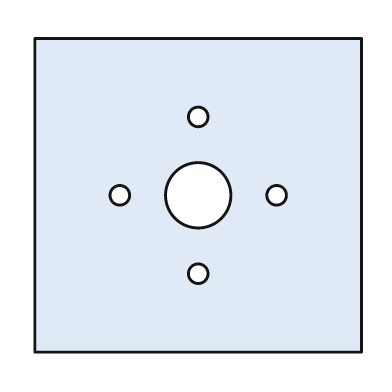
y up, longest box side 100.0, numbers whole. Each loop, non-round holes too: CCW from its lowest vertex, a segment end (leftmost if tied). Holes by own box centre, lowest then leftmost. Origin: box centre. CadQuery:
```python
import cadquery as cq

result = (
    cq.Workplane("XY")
    .moveTo(-50.0, -48.0)
    .lineTo(50.0, -48.0)
    .lineTo(50.0, 48.0)
    .lineTo(-50.0, 48.0)
    .close()
    .moveTo(0.0, -24.0)
    .circle(3.0)
    .moveTo(-24.0, 0.0)
    .circle(3.0)
    .moveTo(0.0, 0.0)
    .circle(10.0)
    .moveTo(24.0, 0.0)
    .circle(3.0)
    .moveTo(0.0, 24.0)
    .circle(3.0)
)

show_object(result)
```